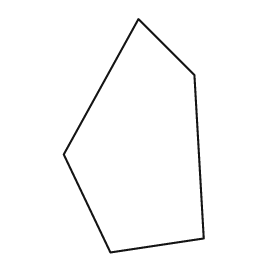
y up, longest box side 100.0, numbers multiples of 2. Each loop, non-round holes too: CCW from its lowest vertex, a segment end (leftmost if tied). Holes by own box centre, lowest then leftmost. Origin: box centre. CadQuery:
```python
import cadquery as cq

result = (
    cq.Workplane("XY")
    .moveTo(-10.0, -50.0)
    .lineTo(30.0, -44.0)
    .lineTo(26.0, 26.0)
    .lineTo(2.0, 50.0)
    .lineTo(-30.0, -8.0)
    .close()
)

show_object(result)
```